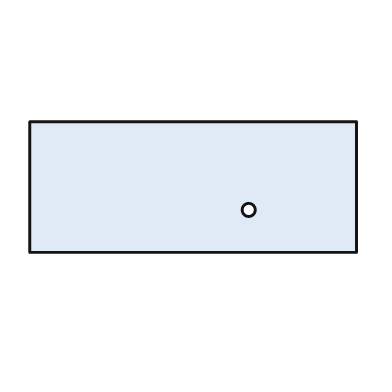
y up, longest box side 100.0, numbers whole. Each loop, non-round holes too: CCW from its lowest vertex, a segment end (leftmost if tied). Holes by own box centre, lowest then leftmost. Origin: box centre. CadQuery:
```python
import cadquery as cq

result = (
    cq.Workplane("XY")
    .moveTo(-50.0, -20.0)
    .lineTo(50.0, -20.0)
    .lineTo(50.0, 20.0)
    .lineTo(-50.0, 20.0)
    .close()
    .moveTo(17.0, -7.0)
    .circle(2.0)
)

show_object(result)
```